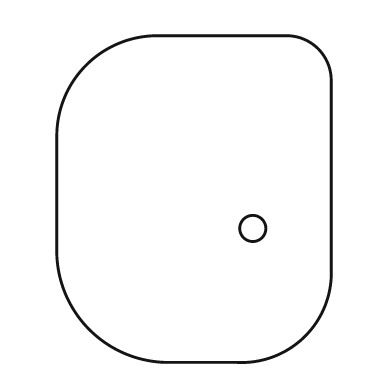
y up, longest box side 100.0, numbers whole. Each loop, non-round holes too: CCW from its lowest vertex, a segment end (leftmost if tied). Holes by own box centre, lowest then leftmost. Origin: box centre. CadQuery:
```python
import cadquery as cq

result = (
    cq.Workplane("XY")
    .moveTo(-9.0, -50.0)
    .lineTo(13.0, -50.0)
    .threePointArc((34.0, -42.0), (42.0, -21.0))
    .lineTo(42.0, 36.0)
    .threePointArc((38.0, 46.0), (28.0, 50.0))
    .lineTo(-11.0, 50.0)
    .threePointArc((-33.0, 41.0), (-42.0, 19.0))
    .lineTo(-42.0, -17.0)
    .threePointArc((-32.0, -40.0), (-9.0, -50.0))
    .close()
    .moveTo(18.0, -9.0)
    .circle(4.0)
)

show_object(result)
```